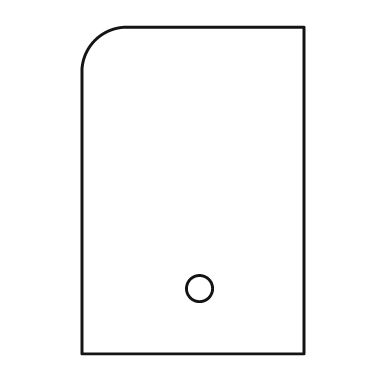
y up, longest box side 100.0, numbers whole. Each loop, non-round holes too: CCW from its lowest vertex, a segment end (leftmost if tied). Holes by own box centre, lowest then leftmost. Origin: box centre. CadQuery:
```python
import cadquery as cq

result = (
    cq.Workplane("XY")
    .moveTo(-34.0, -50.0)
    .lineTo(34.0, -50.0)
    .lineTo(34.0, 50.0)
    .lineTo(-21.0, 50.0)
    .threePointArc((-30.0, 46.0), (-34.0, 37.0))
    .close()
    .moveTo(2.0, -30.0)
    .circle(4.0)
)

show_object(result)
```